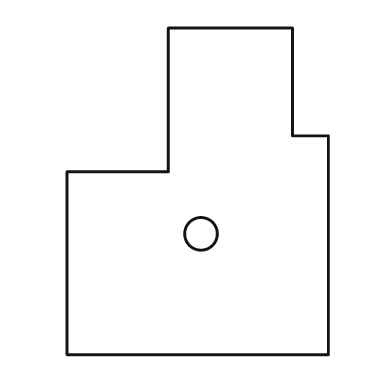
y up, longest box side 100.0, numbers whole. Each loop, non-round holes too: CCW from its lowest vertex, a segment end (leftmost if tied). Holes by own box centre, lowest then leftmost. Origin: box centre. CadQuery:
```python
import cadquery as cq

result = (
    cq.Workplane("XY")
    .moveTo(-40.0, -50.0)
    .lineTo(40.0, -50.0)
    .lineTo(40.0, 17.0)
    .lineTo(29.0, 17.0)
    .lineTo(29.0, 50.0)
    .lineTo(-9.0, 50.0)
    .lineTo(-9.0, 6.0)
    .lineTo(-40.0, 6.0)
    .close()
    .moveTo(1.0, -13.0)
    .circle(5.0)
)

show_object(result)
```